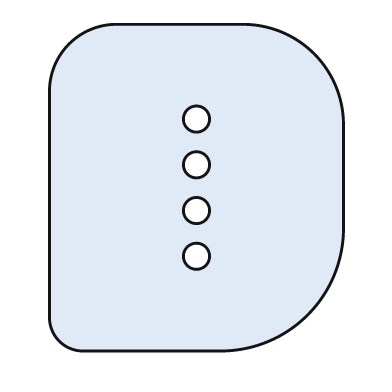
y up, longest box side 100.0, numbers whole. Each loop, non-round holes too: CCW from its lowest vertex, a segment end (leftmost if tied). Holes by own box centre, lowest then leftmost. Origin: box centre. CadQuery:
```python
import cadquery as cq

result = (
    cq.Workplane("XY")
    .moveTo(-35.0, -50.0)
    .lineTo(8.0, -50.0)
    .threePointArc((34.0, -39.0), (45.0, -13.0))
    .lineTo(45.0, 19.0)
    .threePointArc((36.0, 41.0), (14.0, 50.0))
    .lineTo(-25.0, 50.0)
    .threePointArc((-39.0, 44.0), (-45.0, 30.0))
    .lineTo(-45.0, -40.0)
    .threePointArc((-42.0, -47.0), (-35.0, -50.0))
    .close()
    .moveTo(0.0, -21.0)
    .circle(4.0)
    .moveTo(0.0, -7.0)
    .circle(4.0)
    .moveTo(0.0, 7.0)
    .circle(4.0)
    .moveTo(0.0, 21.0)
    .circle(4.0)
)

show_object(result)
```